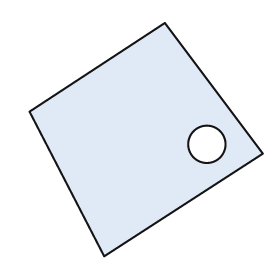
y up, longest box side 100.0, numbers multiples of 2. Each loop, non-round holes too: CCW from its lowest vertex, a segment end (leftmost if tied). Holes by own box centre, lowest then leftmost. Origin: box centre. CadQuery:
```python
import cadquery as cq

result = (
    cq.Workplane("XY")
    .moveTo(-18.0, -50.0)
    .lineTo(50.0, -6.0)
    .lineTo(8.0, 50.0)
    .lineTo(-50.0, 12.0)
    .close()
    .moveTo(26.0, -2.0)
    .circle(8.0)
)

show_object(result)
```